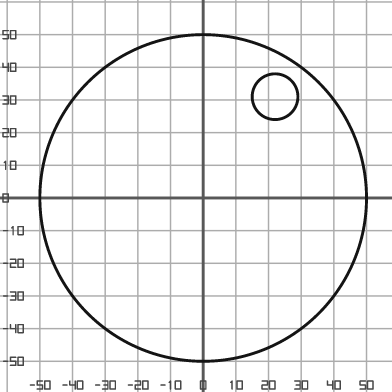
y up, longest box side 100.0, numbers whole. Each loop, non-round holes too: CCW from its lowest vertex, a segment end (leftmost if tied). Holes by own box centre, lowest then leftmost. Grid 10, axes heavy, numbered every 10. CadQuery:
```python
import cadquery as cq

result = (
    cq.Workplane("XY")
    .moveTo(0.0, 0.0)
    .circle(50.0)
    .moveTo(22.0, 31.0)
    .circle(7.0)
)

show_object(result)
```